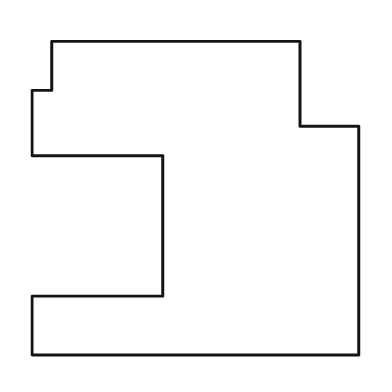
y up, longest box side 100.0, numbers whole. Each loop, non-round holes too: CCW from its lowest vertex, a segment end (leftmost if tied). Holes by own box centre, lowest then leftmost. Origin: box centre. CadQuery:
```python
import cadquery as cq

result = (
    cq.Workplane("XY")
    .moveTo(-50.0, -48.0)
    .lineTo(50.0, -48.0)
    .lineTo(50.0, 22.0)
    .lineTo(32.0, 22.0)
    .lineTo(32.0, 48.0)
    .lineTo(-44.0, 48.0)
    .lineTo(-44.0, 33.0)
    .lineTo(-50.0, 33.0)
    .lineTo(-50.0, 13.0)
    .lineTo(-10.0, 13.0)
    .lineTo(-10.0, -30.0)
    .lineTo(-50.0, -30.0)
    .close()
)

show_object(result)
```